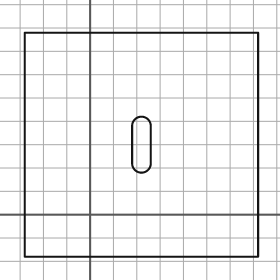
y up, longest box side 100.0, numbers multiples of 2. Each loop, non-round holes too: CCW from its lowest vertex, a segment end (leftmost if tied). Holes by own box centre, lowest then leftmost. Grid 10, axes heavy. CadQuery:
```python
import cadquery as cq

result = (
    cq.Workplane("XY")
    .moveTo(-28.0, -18.0)
    .lineTo(72.0, -18.0)
    .lineTo(72.0, 78.0)
    .lineTo(-28.0, 78.0)
    .close()
    .moveTo(18.0, 22.0)
    .threePointArc((22.0, 18.0), (26.0, 22.0))
    .lineTo(26.0, 38.0)
    .threePointArc((22.0, 42.0), (18.0, 38.0))
    .close()
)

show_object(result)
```